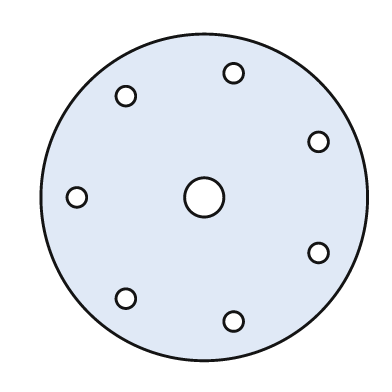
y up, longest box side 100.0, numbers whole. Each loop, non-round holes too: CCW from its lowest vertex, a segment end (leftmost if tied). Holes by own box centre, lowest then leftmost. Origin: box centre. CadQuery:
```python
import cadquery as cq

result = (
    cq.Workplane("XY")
    .moveTo(0.0, 0.0)
    .circle(50.0)
    .moveTo(9.0, -38.0)
    .circle(3.0)
    .moveTo(-24.0, -31.0)
    .circle(3.0)
    .moveTo(35.0, -17.0)
    .circle(3.0)
    .moveTo(-39.0, 0.0)
    .circle(3.0)
    .moveTo(0.0, 0.0)
    .circle(6.0)
    .moveTo(35.0, 17.0)
    .circle(3.0)
    .moveTo(-24.0, 31.0)
    .circle(3.0)
    .moveTo(9.0, 38.0)
    .circle(3.0)
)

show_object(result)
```